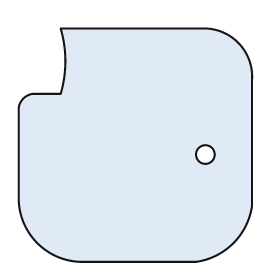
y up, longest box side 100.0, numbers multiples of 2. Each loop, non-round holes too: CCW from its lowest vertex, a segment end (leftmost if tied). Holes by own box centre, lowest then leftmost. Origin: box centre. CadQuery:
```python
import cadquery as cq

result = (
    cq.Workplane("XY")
    .moveTo(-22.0, -50.0)
    .lineTo(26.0, -50.0)
    .threePointArc((42.0, -42.0), (50.0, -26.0))
    .lineTo(50.0, 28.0)
    .threePointArc((44.0, 44.0), (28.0, 50.0))
    .lineTo(-32.0, 50.0)
    .threePointArc((-30.0, 36.0), (-32.0, 22.0))
    .lineTo(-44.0, 22.0)
    .threePointArc((-48.0, 20.0), (-50.0, 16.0))
    .lineTo(-50.0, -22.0)
    .threePointArc((-42.0, -42.0), (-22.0, -50.0))
    .close()
    .moveTo(30.0, -4.0)
    .circle(4.0)
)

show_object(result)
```